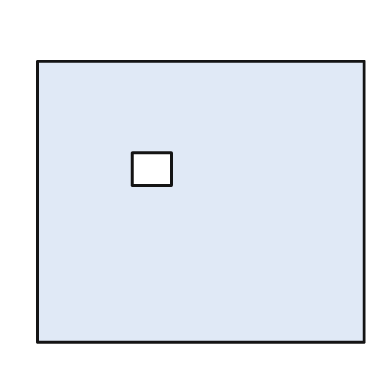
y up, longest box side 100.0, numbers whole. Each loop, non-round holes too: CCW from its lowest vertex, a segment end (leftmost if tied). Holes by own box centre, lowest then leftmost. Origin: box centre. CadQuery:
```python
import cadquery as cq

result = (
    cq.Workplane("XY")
    .moveTo(-50.0, -43.0)
    .lineTo(50.0, -43.0)
    .lineTo(50.0, 43.0)
    .lineTo(-50.0, 43.0)
    .close()
    .moveTo(-21.0, 5.0)
    .lineTo(-9.0, 5.0)
    .lineTo(-9.0, 15.0)
    .lineTo(-21.0, 15.0)
    .close()
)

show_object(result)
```